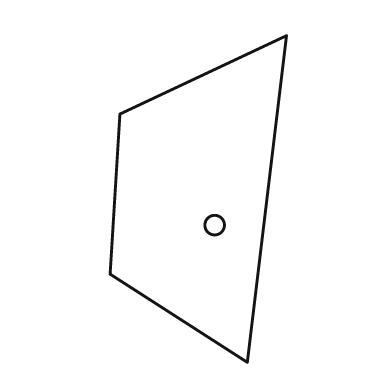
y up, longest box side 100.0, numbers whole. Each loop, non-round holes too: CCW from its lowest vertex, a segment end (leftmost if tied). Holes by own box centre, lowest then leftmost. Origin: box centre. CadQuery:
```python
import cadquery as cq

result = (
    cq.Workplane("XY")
    .moveTo(15.0, -50.0)
    .lineTo(27.0, 50.0)
    .lineTo(-24.0, 26.0)
    .lineTo(-27.0, -23.0)
    .close()
    .moveTo(5.0, -8.0)
    .circle(3.0)
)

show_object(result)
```